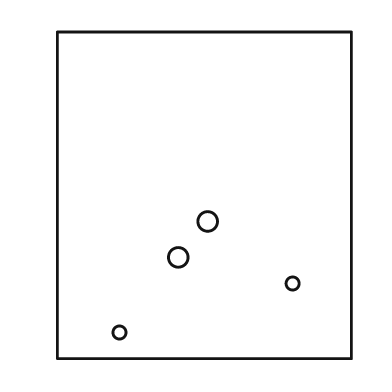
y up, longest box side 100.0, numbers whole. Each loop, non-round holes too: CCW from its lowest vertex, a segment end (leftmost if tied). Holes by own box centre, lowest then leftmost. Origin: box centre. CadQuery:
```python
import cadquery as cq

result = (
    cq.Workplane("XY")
    .moveTo(-45.0, -50.0)
    .lineTo(45.0, -50.0)
    .lineTo(45.0, 50.0)
    .lineTo(-45.0, 50.0)
    .close()
    .moveTo(-26.0, -42.0)
    .circle(2.0)
    .moveTo(27.0, -27.0)
    .circle(2.0)
    .moveTo(-8.0, -19.0)
    .circle(3.0)
    .moveTo(1.0, -8.0)
    .circle(3.0)
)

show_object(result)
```